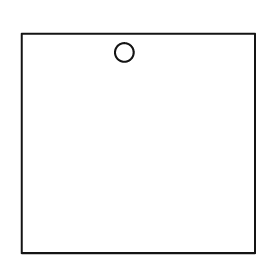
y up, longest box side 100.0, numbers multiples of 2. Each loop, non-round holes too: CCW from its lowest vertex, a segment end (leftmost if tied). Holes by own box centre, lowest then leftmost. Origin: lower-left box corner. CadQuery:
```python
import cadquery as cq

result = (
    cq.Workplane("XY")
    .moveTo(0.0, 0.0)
    .lineTo(100.0, 0.0)
    .lineTo(100.0, 94.0)
    .lineTo(0.0, 94.0)
    .close()
    .moveTo(44.0, 86.0)
    .circle(4.0)
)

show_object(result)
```